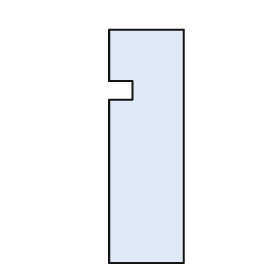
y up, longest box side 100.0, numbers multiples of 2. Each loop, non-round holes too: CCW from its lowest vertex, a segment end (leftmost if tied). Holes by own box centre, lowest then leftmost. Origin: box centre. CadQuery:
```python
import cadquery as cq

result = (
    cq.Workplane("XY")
    .moveTo(-16.0, -50.0)
    .lineTo(16.0, -50.0)
    .lineTo(16.0, 50.0)
    .lineTo(-16.0, 50.0)
    .lineTo(-16.0, 28.0)
    .lineTo(-6.0, 28.0)
    .lineTo(-6.0, 20.0)
    .lineTo(-16.0, 20.0)
    .close()
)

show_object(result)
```